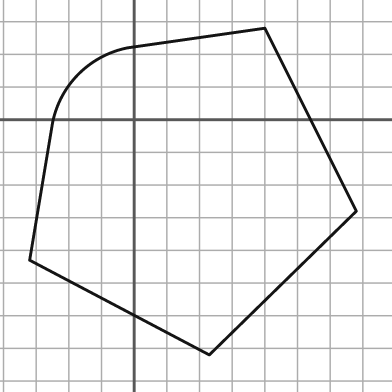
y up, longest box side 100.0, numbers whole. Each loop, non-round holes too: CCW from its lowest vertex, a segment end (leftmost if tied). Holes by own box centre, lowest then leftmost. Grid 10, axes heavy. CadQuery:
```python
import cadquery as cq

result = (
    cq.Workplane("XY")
    .moveTo(23.0, -72.0)
    .lineTo(68.0, -28.0)
    .lineTo(40.0, 28.0)
    .lineTo(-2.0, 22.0)
    .threePointArc((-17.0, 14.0), (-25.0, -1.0))
    .lineTo(-32.0, -43.0)
    .close()
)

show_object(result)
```